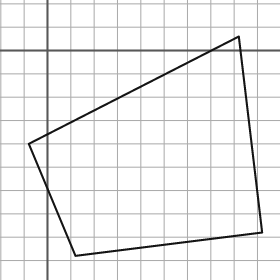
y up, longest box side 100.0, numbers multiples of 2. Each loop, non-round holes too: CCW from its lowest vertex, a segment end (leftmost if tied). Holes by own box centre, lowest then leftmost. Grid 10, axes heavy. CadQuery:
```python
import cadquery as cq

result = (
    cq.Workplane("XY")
    .moveTo(12.0, -88.0)
    .lineTo(92.0, -78.0)
    .lineTo(82.0, 6.0)
    .lineTo(-8.0, -40.0)
    .close()
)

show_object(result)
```